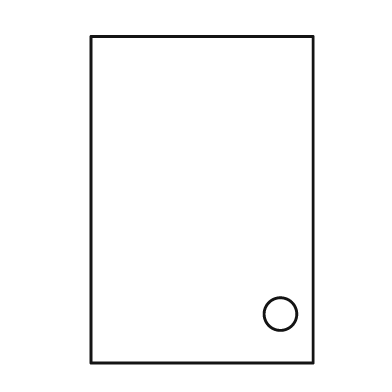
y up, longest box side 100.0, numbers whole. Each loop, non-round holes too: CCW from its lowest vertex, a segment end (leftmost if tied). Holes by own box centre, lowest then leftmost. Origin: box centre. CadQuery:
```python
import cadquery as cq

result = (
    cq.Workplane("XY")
    .moveTo(-34.0, -50.0)
    .lineTo(34.0, -50.0)
    .lineTo(34.0, 50.0)
    .lineTo(-34.0, 50.0)
    .close()
    .moveTo(24.0, -35.0)
    .circle(5.0)
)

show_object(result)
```